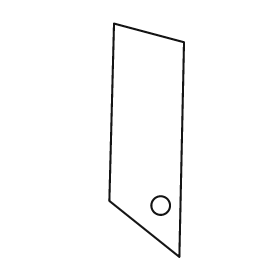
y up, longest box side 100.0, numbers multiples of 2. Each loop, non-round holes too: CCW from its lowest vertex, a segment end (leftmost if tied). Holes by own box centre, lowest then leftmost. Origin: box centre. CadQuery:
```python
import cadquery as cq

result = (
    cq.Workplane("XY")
    .moveTo(14.0, -50.0)
    .lineTo(16.0, 42.0)
    .lineTo(-14.0, 50.0)
    .lineTo(-16.0, -26.0)
    .close()
    .moveTo(6.0, -28.0)
    .circle(4.0)
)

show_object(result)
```